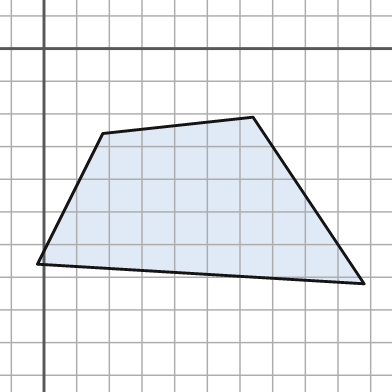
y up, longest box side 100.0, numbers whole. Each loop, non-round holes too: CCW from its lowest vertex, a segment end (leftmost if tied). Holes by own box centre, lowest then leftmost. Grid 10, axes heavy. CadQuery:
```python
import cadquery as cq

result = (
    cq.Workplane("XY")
    .moveTo(98.0, -72.0)
    .lineTo(64.0, -21.0)
    .lineTo(18.0, -26.0)
    .lineTo(-2.0, -66.0)
    .close()
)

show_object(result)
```